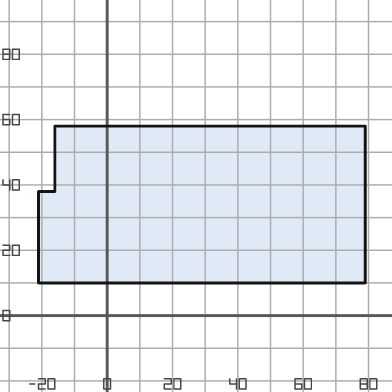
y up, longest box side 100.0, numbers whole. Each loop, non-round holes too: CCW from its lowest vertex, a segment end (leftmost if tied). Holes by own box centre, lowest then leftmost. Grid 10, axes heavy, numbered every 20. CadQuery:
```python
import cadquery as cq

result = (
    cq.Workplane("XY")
    .moveTo(-21.0, 10.0)
    .lineTo(79.0, 10.0)
    .lineTo(79.0, 58.0)
    .lineTo(-16.0, 58.0)
    .lineTo(-16.0, 38.0)
    .lineTo(-21.0, 38.0)
    .close()
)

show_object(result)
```